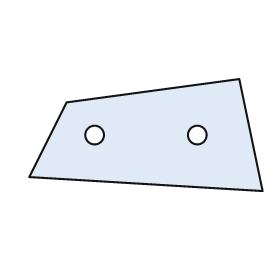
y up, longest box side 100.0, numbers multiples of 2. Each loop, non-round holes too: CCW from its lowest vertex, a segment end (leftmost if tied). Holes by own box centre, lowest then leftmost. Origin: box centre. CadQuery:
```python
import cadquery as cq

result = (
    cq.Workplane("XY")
    .moveTo(50.0, -24.0)
    .lineTo(40.0, 24.0)
    .lineTo(-34.0, 14.0)
    .lineTo(-50.0, -18.0)
    .close()
    .moveTo(-22.0, 0.0)
    .circle(4.0)
    .moveTo(22.0, 0.0)
    .circle(4.0)
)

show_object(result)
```